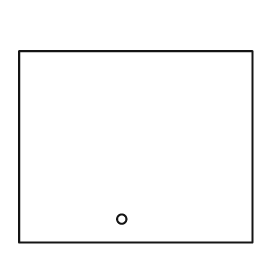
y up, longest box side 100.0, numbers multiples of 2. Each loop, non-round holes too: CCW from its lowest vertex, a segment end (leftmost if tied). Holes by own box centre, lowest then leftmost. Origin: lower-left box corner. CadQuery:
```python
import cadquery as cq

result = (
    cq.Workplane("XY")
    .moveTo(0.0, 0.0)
    .lineTo(100.0, 0.0)
    .lineTo(100.0, 82.0)
    .lineTo(0.0, 82.0)
    .close()
    .moveTo(44.0, 10.0)
    .circle(2.0)
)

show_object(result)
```